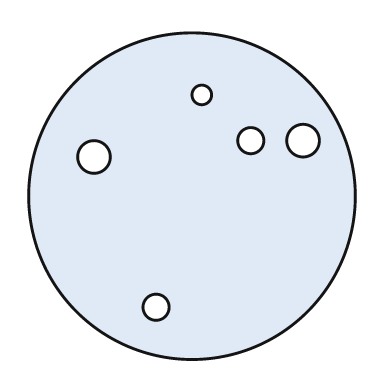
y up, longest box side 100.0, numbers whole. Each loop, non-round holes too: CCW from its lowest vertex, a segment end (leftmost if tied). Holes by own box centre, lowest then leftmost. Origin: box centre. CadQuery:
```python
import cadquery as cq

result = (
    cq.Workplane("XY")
    .moveTo(0.0, 0.0)
    .circle(50.0)
    .moveTo(-11.0, -34.0)
    .circle(4.0)
    .moveTo(-30.0, 12.0)
    .circle(5.0)
    .moveTo(18.0, 17.0)
    .circle(4.0)
    .moveTo(34.0, 17.0)
    .circle(5.0)
    .moveTo(3.0, 31.0)
    .circle(3.0)
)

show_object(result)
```